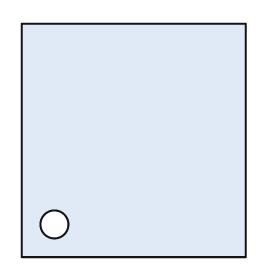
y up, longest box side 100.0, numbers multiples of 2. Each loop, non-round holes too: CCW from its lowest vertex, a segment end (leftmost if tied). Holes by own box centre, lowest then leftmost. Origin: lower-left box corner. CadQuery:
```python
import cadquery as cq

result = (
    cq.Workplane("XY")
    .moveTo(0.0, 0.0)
    .lineTo(96.0, 0.0)
    .lineTo(96.0, 100.0)
    .lineTo(0.0, 100.0)
    .close()
    .moveTo(14.0, 14.0)
    .circle(6.0)
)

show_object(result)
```